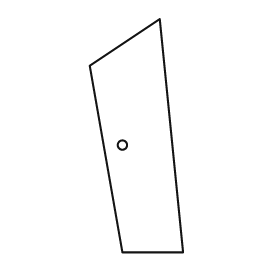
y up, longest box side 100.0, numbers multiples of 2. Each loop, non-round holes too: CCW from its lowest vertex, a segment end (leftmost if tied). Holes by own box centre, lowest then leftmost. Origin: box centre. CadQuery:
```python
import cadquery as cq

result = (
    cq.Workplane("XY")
    .moveTo(-6.0, -50.0)
    .lineTo(20.0, -50.0)
    .lineTo(10.0, 50.0)
    .lineTo(-20.0, 30.0)
    .close()
    .moveTo(-6.0, -4.0)
    .circle(2.0)
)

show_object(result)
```